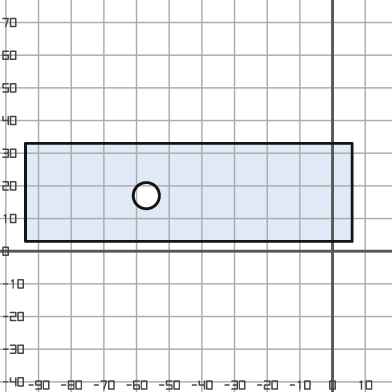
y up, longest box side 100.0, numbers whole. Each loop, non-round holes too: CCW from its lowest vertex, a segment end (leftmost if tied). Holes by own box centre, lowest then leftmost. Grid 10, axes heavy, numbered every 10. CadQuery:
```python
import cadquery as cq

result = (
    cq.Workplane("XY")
    .moveTo(-94.0, 3.0)
    .lineTo(6.0, 3.0)
    .lineTo(6.0, 33.0)
    .lineTo(-94.0, 33.0)
    .close()
    .moveTo(-57.0, 17.0)
    .circle(4.0)
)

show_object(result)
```